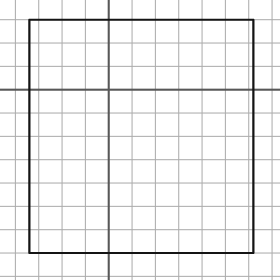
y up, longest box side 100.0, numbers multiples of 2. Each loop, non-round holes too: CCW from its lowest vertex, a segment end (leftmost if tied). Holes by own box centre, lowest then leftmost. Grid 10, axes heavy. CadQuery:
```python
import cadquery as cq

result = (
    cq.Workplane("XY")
    .moveTo(-34.0, -70.0)
    .lineTo(62.0, -70.0)
    .lineTo(62.0, 30.0)
    .lineTo(-34.0, 30.0)
    .close()
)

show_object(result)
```